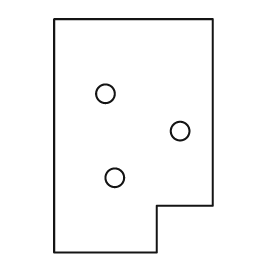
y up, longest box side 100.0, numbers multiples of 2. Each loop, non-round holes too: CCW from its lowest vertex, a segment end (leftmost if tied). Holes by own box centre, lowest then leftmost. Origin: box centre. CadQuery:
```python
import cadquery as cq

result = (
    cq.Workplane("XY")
    .moveTo(-34.0, -50.0)
    .lineTo(10.0, -50.0)
    .lineTo(10.0, -30.0)
    .lineTo(34.0, -30.0)
    .lineTo(34.0, 50.0)
    .lineTo(-34.0, 50.0)
    .close()
    .moveTo(-8.0, -18.0)
    .circle(4.0)
    .moveTo(20.0, 2.0)
    .circle(4.0)
    .moveTo(-12.0, 18.0)
    .circle(4.0)
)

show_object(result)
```